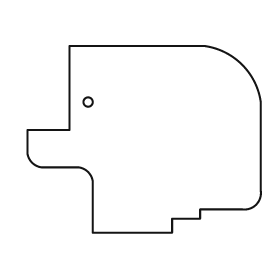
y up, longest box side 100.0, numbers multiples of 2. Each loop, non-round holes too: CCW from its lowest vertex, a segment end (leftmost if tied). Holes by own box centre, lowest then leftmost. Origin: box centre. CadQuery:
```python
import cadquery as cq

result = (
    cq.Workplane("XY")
    .moveTo(-22.0, -40.0)
    .lineTo(12.0, -40.0)
    .lineTo(12.0, -34.0)
    .lineTo(24.0, -34.0)
    .lineTo(24.0, -30.0)
    .lineTo(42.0, -30.0)
    .threePointArc((48.0, -28.0), (50.0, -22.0))
    .lineTo(50.0, 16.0)
    .threePointArc((42.0, 32.0), (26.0, 40.0))
    .lineTo(-32.0, 40.0)
    .lineTo(-32.0, 4.0)
    .lineTo(-50.0, 4.0)
    .lineTo(-50.0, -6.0)
    .threePointArc((-48.0, -10.0), (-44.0, -12.0))
    .lineTo(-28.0, -12.0)
    .threePointArc((-24.0, -14.0), (-22.0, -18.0))
    .close()
    .moveTo(-24.0, 16.0)
    .circle(2.0)
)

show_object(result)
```